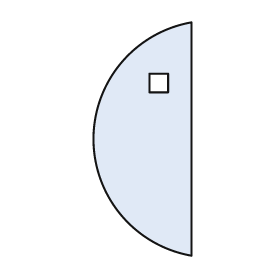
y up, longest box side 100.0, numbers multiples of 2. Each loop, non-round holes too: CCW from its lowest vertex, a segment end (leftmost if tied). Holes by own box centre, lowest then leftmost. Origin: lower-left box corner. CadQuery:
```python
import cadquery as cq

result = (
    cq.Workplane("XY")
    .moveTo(42.0, 0.0)
    .lineTo(42.0, 100.0)
    .threePointArc((0.0, 50.0), (42.0, 0.0))
    .close()
    .moveTo(24.0, 70.0)
    .lineTo(32.0, 70.0)
    .lineTo(32.0, 78.0)
    .lineTo(24.0, 78.0)
    .close()
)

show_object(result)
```